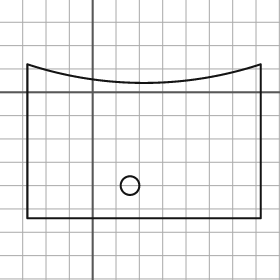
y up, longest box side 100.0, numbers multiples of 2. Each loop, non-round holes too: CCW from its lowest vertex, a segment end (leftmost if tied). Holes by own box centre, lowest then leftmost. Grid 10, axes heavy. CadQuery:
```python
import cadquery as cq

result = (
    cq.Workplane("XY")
    .moveTo(-28.0, -54.0)
    .lineTo(72.0, -54.0)
    .lineTo(72.0, 12.0)
    .threePointArc((22.0, 4.0), (-28.0, 12.0))
    .close()
    .moveTo(16.0, -40.0)
    .circle(4.0)
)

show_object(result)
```